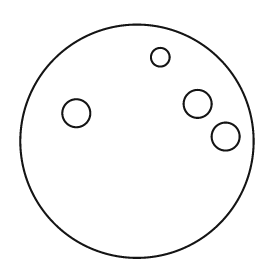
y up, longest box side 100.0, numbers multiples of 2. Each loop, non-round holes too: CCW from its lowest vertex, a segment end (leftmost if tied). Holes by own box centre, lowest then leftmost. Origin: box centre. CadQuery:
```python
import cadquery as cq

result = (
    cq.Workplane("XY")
    .moveTo(0.0, 0.0)
    .circle(50.0)
    .moveTo(38.0, 2.0)
    .circle(6.0)
    .moveTo(-26.0, 12.0)
    .circle(6.0)
    .moveTo(26.0, 16.0)
    .circle(6.0)
    .moveTo(10.0, 36.0)
    .circle(4.0)
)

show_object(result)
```